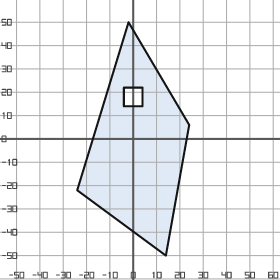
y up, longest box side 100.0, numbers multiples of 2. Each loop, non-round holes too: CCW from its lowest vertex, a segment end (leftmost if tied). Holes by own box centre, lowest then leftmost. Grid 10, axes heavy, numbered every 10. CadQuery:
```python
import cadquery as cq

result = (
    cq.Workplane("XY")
    .moveTo(14.0, -50.0)
    .lineTo(24.0, 6.0)
    .lineTo(-2.0, 50.0)
    .lineTo(-24.0, -22.0)
    .close()
    .moveTo(-4.0, 14.0)
    .lineTo(4.0, 14.0)
    .lineTo(4.0, 22.0)
    .lineTo(-4.0, 22.0)
    .close()
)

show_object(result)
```